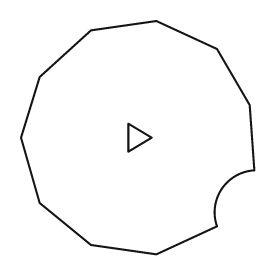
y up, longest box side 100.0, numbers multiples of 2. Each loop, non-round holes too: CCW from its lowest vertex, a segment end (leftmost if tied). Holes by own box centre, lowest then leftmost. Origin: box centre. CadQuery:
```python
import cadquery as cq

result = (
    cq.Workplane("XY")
    .moveTo(8.0, -50.0)
    .lineTo(34.0, -38.0)
    .threePointArc((36.0, -22.0), (50.0, -14.0))
    .lineTo(48.0, 14.0)
    .lineTo(34.0, 38.0)
    .lineTo(8.0, 50.0)
    .lineTo(-20.0, 46.0)
    .lineTo(-42.0, 26.0)
    .lineTo(-50.0, 0.0)
    .lineTo(-42.0, -28.0)
    .lineTo(-20.0, -46.0)
    .close()
    .moveTo(-4.0, -6.0)
    .lineTo(6.0, 0.0)
    .lineTo(-4.0, 6.0)
    .close()
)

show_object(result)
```